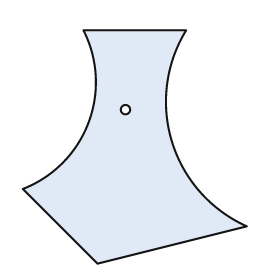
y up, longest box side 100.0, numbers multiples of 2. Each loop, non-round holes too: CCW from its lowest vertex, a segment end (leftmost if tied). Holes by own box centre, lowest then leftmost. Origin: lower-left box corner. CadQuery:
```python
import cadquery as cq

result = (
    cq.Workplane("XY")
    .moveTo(32.0, 0.0)
    .lineTo(96.0, 16.0)
    .threePointArc((64.0, 52.0), (70.0, 100.0))
    .lineTo(26.0, 100.0)
    .threePointArc((28.0, 60.0), (0.0, 32.0))
    .close()
    .moveTo(44.0, 66.0)
    .circle(2.0)
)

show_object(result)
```